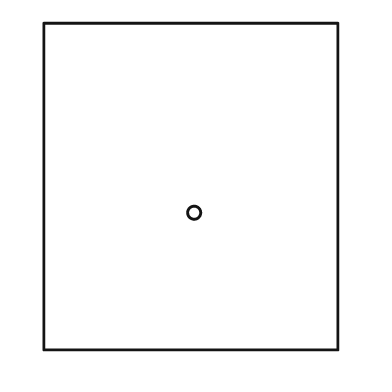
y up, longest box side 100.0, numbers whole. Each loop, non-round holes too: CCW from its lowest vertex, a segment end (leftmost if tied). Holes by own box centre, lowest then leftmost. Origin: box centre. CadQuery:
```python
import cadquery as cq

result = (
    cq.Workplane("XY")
    .moveTo(-45.0, -50.0)
    .lineTo(45.0, -50.0)
    .lineTo(45.0, 50.0)
    .lineTo(-45.0, 50.0)
    .close()
    .moveTo(1.0, -8.0)
    .circle(2.0)
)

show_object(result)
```